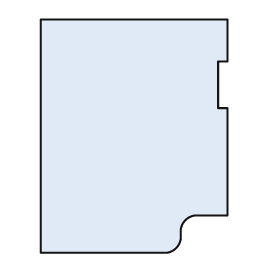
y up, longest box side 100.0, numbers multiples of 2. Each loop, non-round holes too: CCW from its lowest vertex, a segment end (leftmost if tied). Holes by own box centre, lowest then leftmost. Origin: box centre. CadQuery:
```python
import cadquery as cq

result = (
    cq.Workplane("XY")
    .moveTo(-40.0, -50.0)
    .lineTo(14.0, -50.0)
    .threePointArc((18.0, -48.0), (20.0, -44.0))
    .lineTo(20.0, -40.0)
    .threePointArc((22.0, -36.0), (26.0, -34.0))
    .lineTo(40.0, -34.0)
    .lineTo(40.0, 12.0)
    .lineTo(36.0, 12.0)
    .lineTo(36.0, 32.0)
    .lineTo(40.0, 32.0)
    .lineTo(40.0, 50.0)
    .lineTo(-40.0, 50.0)
    .close()
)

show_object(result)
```